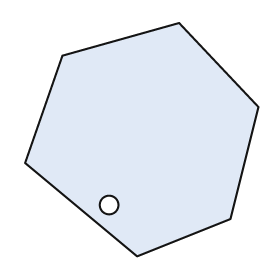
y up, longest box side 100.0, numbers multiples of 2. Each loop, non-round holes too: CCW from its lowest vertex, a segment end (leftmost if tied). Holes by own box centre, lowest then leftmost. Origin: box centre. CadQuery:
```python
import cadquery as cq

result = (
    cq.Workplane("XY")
    .moveTo(-2.0, -50.0)
    .lineTo(38.0, -34.0)
    .lineTo(50.0, 14.0)
    .lineTo(16.0, 50.0)
    .lineTo(-34.0, 36.0)
    .lineTo(-50.0, -10.0)
    .close()
    .moveTo(-14.0, -28.0)
    .circle(4.0)
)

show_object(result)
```